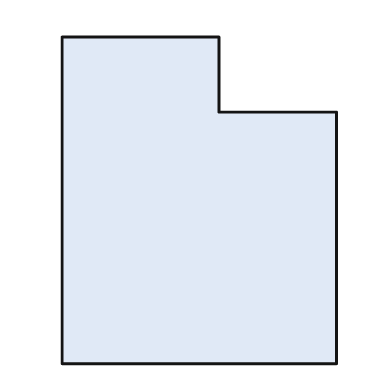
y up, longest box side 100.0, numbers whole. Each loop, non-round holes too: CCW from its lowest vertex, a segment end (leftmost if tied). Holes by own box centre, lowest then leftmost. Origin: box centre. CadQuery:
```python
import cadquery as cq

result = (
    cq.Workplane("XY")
    .moveTo(-42.0, -50.0)
    .lineTo(42.0, -50.0)
    .lineTo(42.0, 27.0)
    .lineTo(6.0, 27.0)
    .lineTo(6.0, 50.0)
    .lineTo(-42.0, 50.0)
    .close()
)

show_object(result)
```